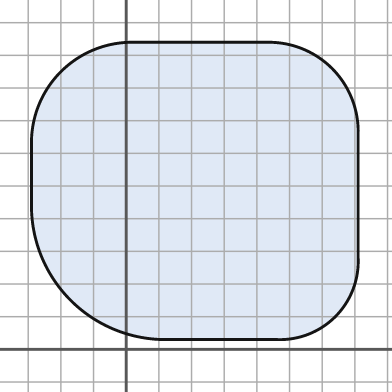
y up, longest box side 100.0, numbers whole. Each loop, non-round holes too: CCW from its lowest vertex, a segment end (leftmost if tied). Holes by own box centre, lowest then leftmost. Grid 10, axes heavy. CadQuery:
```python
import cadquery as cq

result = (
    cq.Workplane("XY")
    .moveTo(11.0, 3.0)
    .lineTo(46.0, 3.0)
    .threePointArc((64.0, 10.0), (71.0, 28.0))
    .lineTo(71.0, 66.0)
    .threePointArc((63.0, 86.0), (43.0, 94.0))
    .lineTo(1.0, 94.0)
    .threePointArc((-20.0, 85.0), (-29.0, 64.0))
    .lineTo(-29.0, 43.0)
    .threePointArc((-17.0, 15.0), (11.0, 3.0))
    .close()
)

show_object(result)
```